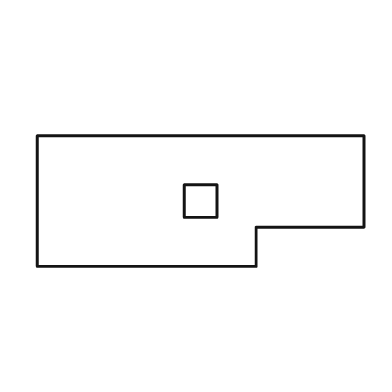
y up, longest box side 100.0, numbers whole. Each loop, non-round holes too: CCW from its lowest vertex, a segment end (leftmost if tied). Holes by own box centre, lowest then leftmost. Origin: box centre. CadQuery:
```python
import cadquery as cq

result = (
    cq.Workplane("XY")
    .moveTo(-50.0, -20.0)
    .lineTo(17.0, -20.0)
    .lineTo(17.0, -8.0)
    .lineTo(50.0, -8.0)
    .lineTo(50.0, 20.0)
    .lineTo(-50.0, 20.0)
    .close()
    .moveTo(-5.0, -5.0)
    .lineTo(5.0, -5.0)
    .lineTo(5.0, 5.0)
    .lineTo(-5.0, 5.0)
    .close()
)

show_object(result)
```